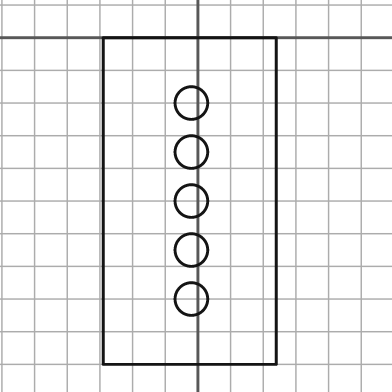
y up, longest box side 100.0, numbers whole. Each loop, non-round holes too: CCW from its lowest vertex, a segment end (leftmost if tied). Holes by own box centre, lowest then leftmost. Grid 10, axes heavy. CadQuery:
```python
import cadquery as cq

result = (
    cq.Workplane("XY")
    .moveTo(-29.0, -100.0)
    .lineTo(24.0, -100.0)
    .lineTo(24.0, 0.0)
    .lineTo(-29.0, 0.0)
    .close()
    .moveTo(-2.0, -80.0)
    .circle(5.0)
    .moveTo(-2.0, -65.0)
    .circle(5.0)
    .moveTo(-2.0, -50.0)
    .circle(5.0)
    .moveTo(-2.0, -35.0)
    .circle(5.0)
    .moveTo(-2.0, -20.0)
    .circle(5.0)
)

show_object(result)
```